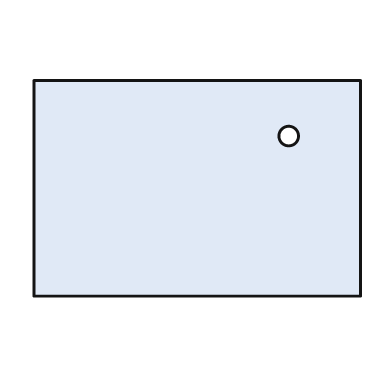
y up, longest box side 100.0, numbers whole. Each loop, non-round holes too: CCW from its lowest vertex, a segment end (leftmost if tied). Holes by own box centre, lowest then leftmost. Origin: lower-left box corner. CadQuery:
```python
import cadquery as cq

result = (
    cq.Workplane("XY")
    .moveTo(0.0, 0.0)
    .lineTo(100.0, 0.0)
    .lineTo(100.0, 66.0)
    .lineTo(0.0, 66.0)
    .close()
    .moveTo(78.0, 49.0)
    .circle(3.0)
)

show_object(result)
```